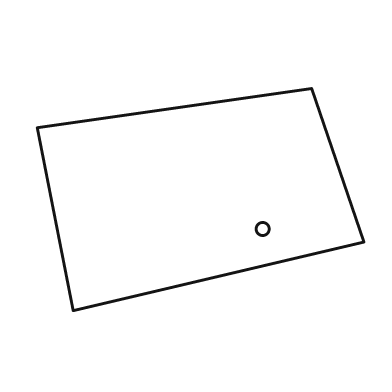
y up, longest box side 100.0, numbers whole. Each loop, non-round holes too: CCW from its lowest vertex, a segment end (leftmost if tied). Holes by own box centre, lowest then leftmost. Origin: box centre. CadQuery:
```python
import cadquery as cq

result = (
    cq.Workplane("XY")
    .moveTo(-39.0, -34.0)
    .lineTo(50.0, -13.0)
    .lineTo(34.0, 34.0)
    .lineTo(-50.0, 22.0)
    .close()
    .moveTo(19.0, -9.0)
    .circle(2.0)
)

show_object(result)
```